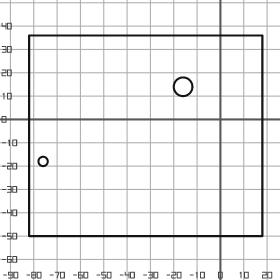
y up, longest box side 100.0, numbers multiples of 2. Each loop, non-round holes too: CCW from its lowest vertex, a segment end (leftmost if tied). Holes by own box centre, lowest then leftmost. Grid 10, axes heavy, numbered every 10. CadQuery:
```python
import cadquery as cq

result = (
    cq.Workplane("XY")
    .moveTo(-82.0, -50.0)
    .lineTo(18.0, -50.0)
    .lineTo(18.0, 36.0)
    .lineTo(-82.0, 36.0)
    .close()
    .moveTo(-76.0, -18.0)
    .circle(2.0)
    .moveTo(-16.0, 14.0)
    .circle(4.0)
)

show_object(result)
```